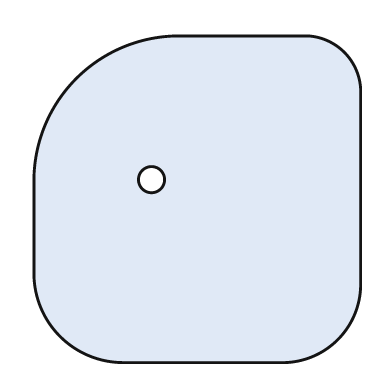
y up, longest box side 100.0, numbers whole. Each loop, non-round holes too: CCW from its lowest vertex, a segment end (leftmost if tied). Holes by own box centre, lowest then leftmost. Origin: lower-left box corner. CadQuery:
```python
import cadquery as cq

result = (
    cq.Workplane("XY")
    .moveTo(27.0, 0.0)
    .lineTo(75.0, 0.0)
    .threePointArc((93.0, 7.0), (100.0, 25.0))
    .lineTo(100.0, 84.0)
    .threePointArc((95.0, 95.0), (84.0, 100.0))
    .lineTo(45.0, 100.0)
    .threePointArc((13.0, 87.0), (0.0, 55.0))
    .lineTo(0.0, 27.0)
    .threePointArc((8.0, 8.0), (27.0, 0.0))
    .close()
    .moveTo(36.0, 56.0)
    .circle(4.0)
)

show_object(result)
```